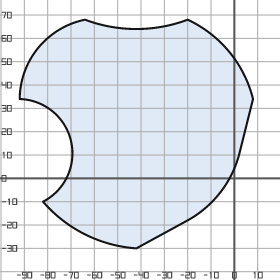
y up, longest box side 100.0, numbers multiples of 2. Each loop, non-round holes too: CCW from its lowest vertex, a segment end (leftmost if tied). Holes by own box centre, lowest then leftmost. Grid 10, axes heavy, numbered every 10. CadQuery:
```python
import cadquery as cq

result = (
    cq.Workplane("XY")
    .moveTo(-42.0, -30.0)
    .lineTo(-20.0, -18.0)
    .threePointArc((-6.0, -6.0), (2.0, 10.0))
    .lineTo(8.0, 34.0)
    .threePointArc((-2.0, 54.0), (-20.0, 68.0))
    .threePointArc((-42.0, 64.0), (-64.0, 68.0))
    .threePointArc((-84.0, 56.0), (-92.0, 34.0))
    .threePointArc((-70.0, 16.0), (-82.0, -10.0))
    .threePointArc((-64.0, -24.0), (-42.0, -30.0))
    .close()
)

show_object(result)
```